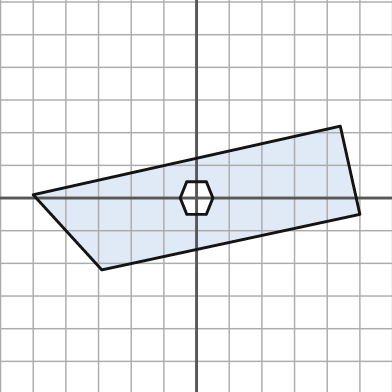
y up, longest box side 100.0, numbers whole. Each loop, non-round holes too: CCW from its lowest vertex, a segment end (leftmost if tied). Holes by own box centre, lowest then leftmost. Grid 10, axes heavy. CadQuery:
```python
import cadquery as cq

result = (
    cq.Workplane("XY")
    .moveTo(-29.0, -22.0)
    .lineTo(50.0, -5.0)
    .lineTo(44.0, 22.0)
    .lineTo(-50.0, 1.0)
    .close()
    .moveTo(-3.0, -5.0)
    .lineTo(3.0, -5.0)
    .lineTo(5.0, 0.0)
    .lineTo(3.0, 5.0)
    .lineTo(-3.0, 5.0)
    .lineTo(-5.0, 0.0)
    .close()
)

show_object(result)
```